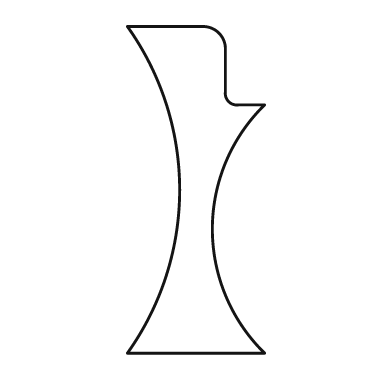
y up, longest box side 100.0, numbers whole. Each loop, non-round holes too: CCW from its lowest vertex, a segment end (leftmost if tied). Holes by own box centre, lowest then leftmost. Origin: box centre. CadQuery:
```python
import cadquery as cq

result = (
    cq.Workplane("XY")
    .moveTo(-21.0, -50.0)
    .lineTo(21.0, -50.0)
    .threePointArc((5.0, -12.0), (21.0, 26.0))
    .lineTo(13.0, 26.0)
    .threePointArc((10.0, 27.0), (9.0, 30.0))
    .lineTo(9.0, 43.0)
    .threePointArc((7.0, 48.0), (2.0, 50.0))
    .lineTo(-21.0, 50.0)
    .threePointArc((-5.0, 0.0), (-21.0, -50.0))
    .close()
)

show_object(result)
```